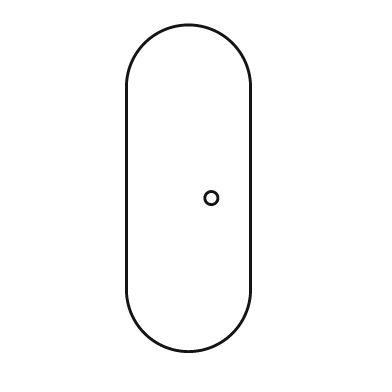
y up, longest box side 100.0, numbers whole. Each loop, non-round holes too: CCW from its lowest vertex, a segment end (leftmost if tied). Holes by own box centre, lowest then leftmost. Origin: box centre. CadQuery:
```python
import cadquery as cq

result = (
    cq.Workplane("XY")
    .moveTo(-19.0, -31.0)
    .threePointArc((0.0, -50.0), (19.0, -31.0))
    .lineTo(19.0, 31.0)
    .threePointArc((0.0, 50.0), (-19.0, 31.0))
    .close()
    .moveTo(7.0, -3.0)
    .circle(2.0)
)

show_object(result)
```